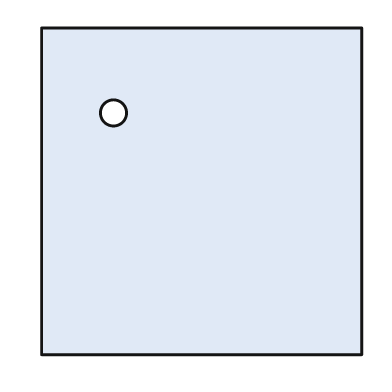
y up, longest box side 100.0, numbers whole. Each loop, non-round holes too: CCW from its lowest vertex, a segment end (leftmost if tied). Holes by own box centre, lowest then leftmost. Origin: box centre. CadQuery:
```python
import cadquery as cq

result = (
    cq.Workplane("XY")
    .moveTo(-49.0, -50.0)
    .lineTo(49.0, -50.0)
    .lineTo(49.0, 50.0)
    .lineTo(-49.0, 50.0)
    .close()
    .moveTo(-27.0, 24.0)
    .circle(4.0)
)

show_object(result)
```